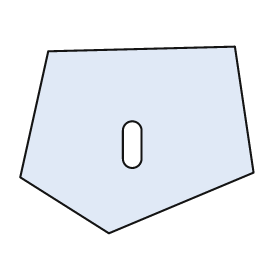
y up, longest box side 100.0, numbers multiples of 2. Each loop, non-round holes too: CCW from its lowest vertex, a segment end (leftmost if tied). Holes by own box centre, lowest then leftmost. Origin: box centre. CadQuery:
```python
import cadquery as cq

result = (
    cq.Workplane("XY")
    .moveTo(-12.0, -40.0)
    .lineTo(50.0, -14.0)
    .lineTo(42.0, 40.0)
    .lineTo(-38.0, 38.0)
    .lineTo(-50.0, -16.0)
    .close()
    .moveTo(-6.0, -8.0)
    .threePointArc((-2.0, -12.0), (2.0, -8.0))
    .lineTo(2.0, 4.0)
    .threePointArc((-2.0, 8.0), (-6.0, 4.0))
    .close()
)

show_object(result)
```